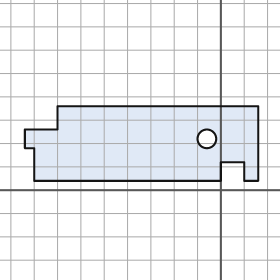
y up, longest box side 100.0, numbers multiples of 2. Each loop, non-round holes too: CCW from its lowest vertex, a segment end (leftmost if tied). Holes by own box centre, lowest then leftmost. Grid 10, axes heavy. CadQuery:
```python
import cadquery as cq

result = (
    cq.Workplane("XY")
    .moveTo(-80.0, 4.0)
    .lineTo(0.0, 4.0)
    .lineTo(0.0, 12.0)
    .lineTo(10.0, 12.0)
    .lineTo(10.0, 4.0)
    .lineTo(16.0, 4.0)
    .lineTo(16.0, 36.0)
    .lineTo(-70.0, 36.0)
    .lineTo(-70.0, 26.0)
    .lineTo(-84.0, 26.0)
    .lineTo(-84.0, 18.0)
    .lineTo(-80.0, 18.0)
    .close()
    .moveTo(-6.0, 22.0)
    .circle(4.0)
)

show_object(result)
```